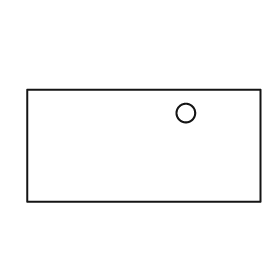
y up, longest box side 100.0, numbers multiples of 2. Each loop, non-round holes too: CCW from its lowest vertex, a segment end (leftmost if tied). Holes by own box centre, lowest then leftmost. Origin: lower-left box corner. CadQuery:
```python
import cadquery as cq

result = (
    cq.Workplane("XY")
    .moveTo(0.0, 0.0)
    .lineTo(100.0, 0.0)
    .lineTo(100.0, 48.0)
    .lineTo(0.0, 48.0)
    .close()
    .moveTo(68.0, 38.0)
    .circle(4.0)
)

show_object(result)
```